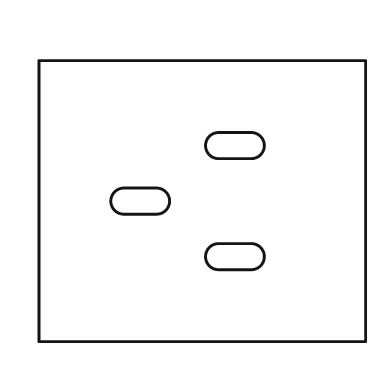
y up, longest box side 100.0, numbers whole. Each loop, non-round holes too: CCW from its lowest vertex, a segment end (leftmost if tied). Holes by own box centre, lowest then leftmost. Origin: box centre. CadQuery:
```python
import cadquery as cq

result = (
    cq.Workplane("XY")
    .moveTo(-50.0, -43.0)
    .lineTo(50.0, -43.0)
    .lineTo(50.0, 43.0)
    .lineTo(-50.0, 43.0)
    .close()
    .moveTo(5.0, -21.0)
    .lineTo(15.0, -21.0)
    .threePointArc((19.0, -17.0), (15.0, -13.0))
    .lineTo(5.0, -13.0)
    .threePointArc((1.0, -17.0), (5.0, -21.0))
    .close()
    .moveTo(-24.0, -4.0)
    .lineTo(-14.0, -4.0)
    .threePointArc((-10.0, 0.0), (-14.0, 4.0))
    .lineTo(-24.0, 4.0)
    .threePointArc((-28.0, 0.0), (-24.0, -4.0))
    .close()
    .moveTo(5.0, 13.0)
    .lineTo(15.0, 13.0)
    .threePointArc((19.0, 17.0), (15.0, 21.0))
    .lineTo(5.0, 21.0)
    .threePointArc((1.0, 17.0), (5.0, 13.0))
    .close()
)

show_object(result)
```